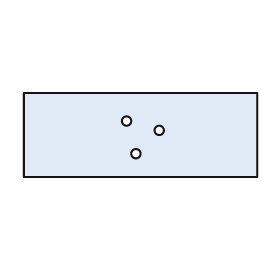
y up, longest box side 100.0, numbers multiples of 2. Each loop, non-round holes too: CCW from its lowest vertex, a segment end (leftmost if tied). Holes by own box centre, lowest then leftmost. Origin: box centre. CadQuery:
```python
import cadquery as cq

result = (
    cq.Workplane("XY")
    .moveTo(-50.0, -18.0)
    .lineTo(50.0, -18.0)
    .lineTo(50.0, 18.0)
    .lineTo(-50.0, 18.0)
    .close()
    .moveTo(-2.0, -8.0)
    .circle(2.0)
    .moveTo(8.0, 2.0)
    .circle(2.0)
    .moveTo(-6.0, 6.0)
    .circle(2.0)
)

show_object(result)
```